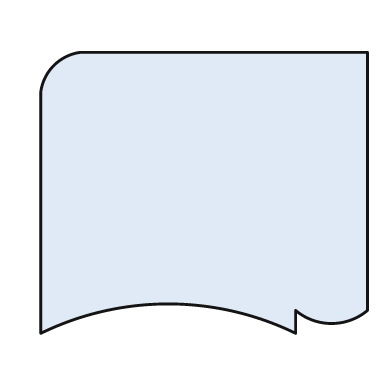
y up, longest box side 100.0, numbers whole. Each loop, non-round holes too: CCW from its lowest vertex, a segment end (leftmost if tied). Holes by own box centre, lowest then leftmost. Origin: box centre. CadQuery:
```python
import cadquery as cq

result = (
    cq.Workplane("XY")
    .moveTo(-50.0, -43.0)
    .threePointArc((-11.0, -34.0), (28.0, -43.0))
    .lineTo(28.0, -36.0)
    .threePointArc((39.0, -40.0), (50.0, -36.0))
    .lineTo(50.0, 43.0)
    .lineTo(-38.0, 43.0)
    .threePointArc((-46.0, 39.0), (-50.0, 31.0))
    .close()
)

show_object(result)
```